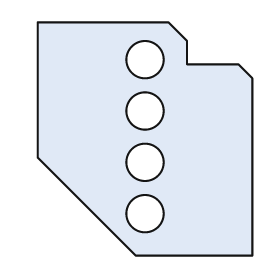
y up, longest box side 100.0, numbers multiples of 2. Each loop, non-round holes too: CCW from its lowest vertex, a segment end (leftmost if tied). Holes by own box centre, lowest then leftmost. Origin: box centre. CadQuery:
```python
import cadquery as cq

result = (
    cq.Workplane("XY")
    .moveTo(-4.0, -50.0)
    .lineTo(46.0, -50.0)
    .lineTo(46.0, 26.0)
    .lineTo(40.0, 32.0)
    .lineTo(18.0, 32.0)
    .lineTo(18.0, 42.0)
    .lineTo(10.0, 50.0)
    .lineTo(-46.0, 50.0)
    .lineTo(-46.0, -8.0)
    .close()
    .moveTo(0.0, -32.0)
    .circle(8.0)
    .moveTo(0.0, -10.0)
    .circle(8.0)
    .moveTo(0.0, 12.0)
    .circle(8.0)
    .moveTo(0.0, 34.0)
    .circle(8.0)
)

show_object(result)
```